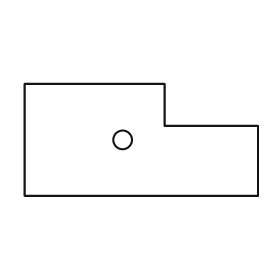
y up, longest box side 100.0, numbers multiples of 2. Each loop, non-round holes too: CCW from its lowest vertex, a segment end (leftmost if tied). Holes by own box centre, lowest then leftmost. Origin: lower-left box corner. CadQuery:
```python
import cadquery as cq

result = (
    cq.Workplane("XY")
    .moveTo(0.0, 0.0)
    .lineTo(100.0, 0.0)
    .lineTo(100.0, 30.0)
    .lineTo(60.0, 30.0)
    .lineTo(60.0, 48.0)
    .lineTo(0.0, 48.0)
    .close()
    .moveTo(42.0, 24.0)
    .circle(4.0)
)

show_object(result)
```